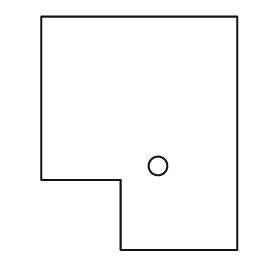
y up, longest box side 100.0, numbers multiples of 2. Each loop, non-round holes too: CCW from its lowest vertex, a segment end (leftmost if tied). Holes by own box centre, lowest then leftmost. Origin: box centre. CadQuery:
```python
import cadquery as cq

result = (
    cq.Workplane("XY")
    .moveTo(-8.0, -50.0)
    .lineTo(42.0, -50.0)
    .lineTo(42.0, 50.0)
    .lineTo(-42.0, 50.0)
    .lineTo(-42.0, -20.0)
    .lineTo(-8.0, -20.0)
    .close()
    .moveTo(8.0, -14.0)
    .circle(4.0)
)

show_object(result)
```